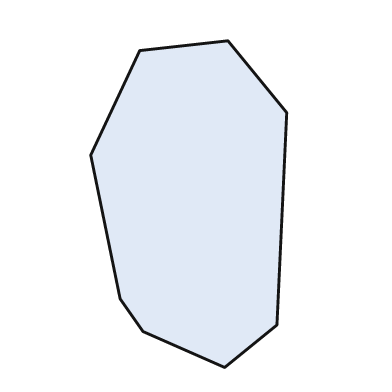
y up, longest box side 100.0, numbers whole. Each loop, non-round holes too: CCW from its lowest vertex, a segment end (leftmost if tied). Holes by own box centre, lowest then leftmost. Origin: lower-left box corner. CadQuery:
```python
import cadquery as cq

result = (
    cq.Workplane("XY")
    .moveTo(41.0, 0.0)
    .lineTo(57.0, 13.0)
    .lineTo(60.0, 78.0)
    .lineTo(42.0, 100.0)
    .lineTo(15.0, 97.0)
    .lineTo(0.0, 65.0)
    .lineTo(9.0, 21.0)
    .lineTo(16.0, 11.0)
    .close()
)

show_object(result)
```